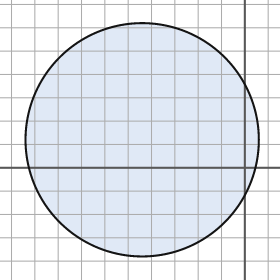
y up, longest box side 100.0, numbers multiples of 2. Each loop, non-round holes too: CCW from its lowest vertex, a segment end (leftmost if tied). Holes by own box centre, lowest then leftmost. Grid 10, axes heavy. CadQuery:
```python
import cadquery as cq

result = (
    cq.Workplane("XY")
    .moveTo(-44.0, 12.0)
    .circle(50.0)
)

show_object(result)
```